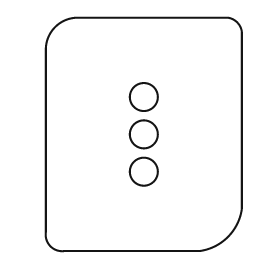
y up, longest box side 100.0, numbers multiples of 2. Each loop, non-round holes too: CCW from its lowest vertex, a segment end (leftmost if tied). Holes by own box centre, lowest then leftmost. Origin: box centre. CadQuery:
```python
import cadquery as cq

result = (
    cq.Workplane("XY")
    .moveTo(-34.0, -50.0)
    .lineTo(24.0, -50.0)
    .threePointArc((36.0, -44.0), (42.0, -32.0))
    .lineTo(42.0, 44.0)
    .threePointArc((40.0, 48.0), (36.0, 50.0))
    .lineTo(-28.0, 50.0)
    .threePointArc((-38.0, 46.0), (-42.0, 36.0))
    .lineTo(-42.0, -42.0)
    .threePointArc((-40.0, -48.0), (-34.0, -50.0))
    .close()
    .moveTo(0.0, -16.0)
    .circle(6.0)
    .moveTo(0.0, 0.0)
    .circle(6.0)
    .moveTo(0.0, 16.0)
    .circle(6.0)
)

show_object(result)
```